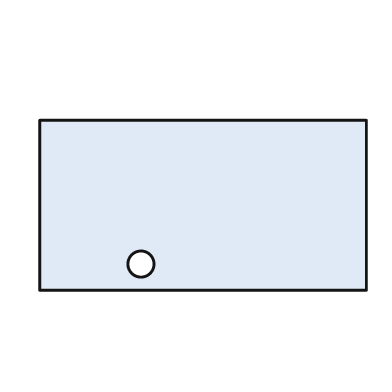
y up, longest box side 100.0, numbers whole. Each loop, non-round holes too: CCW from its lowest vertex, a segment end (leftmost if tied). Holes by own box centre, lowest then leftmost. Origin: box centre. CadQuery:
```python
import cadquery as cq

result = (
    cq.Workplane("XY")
    .moveTo(-50.0, -26.0)
    .lineTo(50.0, -26.0)
    .lineTo(50.0, 26.0)
    .lineTo(-50.0, 26.0)
    .close()
    .moveTo(-19.0, -18.0)
    .circle(4.0)
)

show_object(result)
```